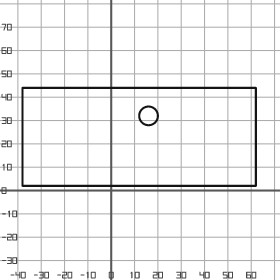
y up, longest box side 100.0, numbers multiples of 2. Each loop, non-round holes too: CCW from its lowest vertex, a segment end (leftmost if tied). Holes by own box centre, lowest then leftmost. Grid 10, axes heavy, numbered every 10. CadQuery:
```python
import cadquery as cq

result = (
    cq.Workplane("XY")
    .moveTo(-38.0, 2.0)
    .lineTo(62.0, 2.0)
    .lineTo(62.0, 44.0)
    .lineTo(-38.0, 44.0)
    .close()
    .moveTo(16.0, 32.0)
    .circle(4.0)
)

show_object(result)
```